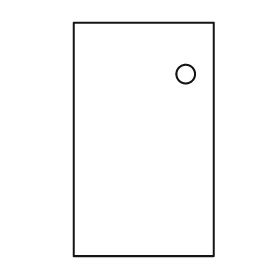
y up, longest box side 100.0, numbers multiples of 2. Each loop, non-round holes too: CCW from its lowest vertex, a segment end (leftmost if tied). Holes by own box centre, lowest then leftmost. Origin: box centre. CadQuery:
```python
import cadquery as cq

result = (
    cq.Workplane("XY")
    .moveTo(-30.0, -50.0)
    .lineTo(30.0, -50.0)
    .lineTo(30.0, 50.0)
    .lineTo(-30.0, 50.0)
    .close()
    .moveTo(18.0, 28.0)
    .circle(4.0)
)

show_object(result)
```